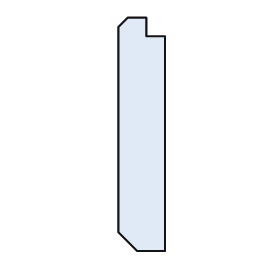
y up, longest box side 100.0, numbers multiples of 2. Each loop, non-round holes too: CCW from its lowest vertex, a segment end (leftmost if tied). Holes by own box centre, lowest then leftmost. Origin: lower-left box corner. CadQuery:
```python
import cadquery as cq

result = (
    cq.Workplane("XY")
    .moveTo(8.0, 0.0)
    .lineTo(20.0, 0.0)
    .lineTo(20.0, 92.0)
    .lineTo(12.0, 92.0)
    .lineTo(12.0, 100.0)
    .lineTo(4.0, 100.0)
    .lineTo(0.0, 96.0)
    .lineTo(0.0, 8.0)
    .close()
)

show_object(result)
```